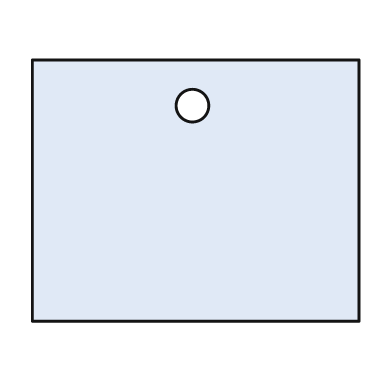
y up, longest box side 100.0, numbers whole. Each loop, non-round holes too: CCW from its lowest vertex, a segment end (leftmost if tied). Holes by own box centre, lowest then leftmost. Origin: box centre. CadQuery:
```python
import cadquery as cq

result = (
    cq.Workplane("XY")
    .moveTo(-50.0, -40.0)
    .lineTo(50.0, -40.0)
    .lineTo(50.0, 40.0)
    .lineTo(-50.0, 40.0)
    .close()
    .moveTo(-1.0, 26.0)
    .circle(5.0)
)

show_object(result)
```